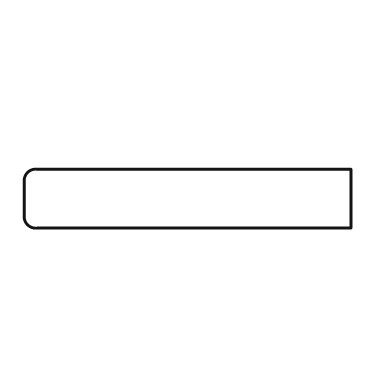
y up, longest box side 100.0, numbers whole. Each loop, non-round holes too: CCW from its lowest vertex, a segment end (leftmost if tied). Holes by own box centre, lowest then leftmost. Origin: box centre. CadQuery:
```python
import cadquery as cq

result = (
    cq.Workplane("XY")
    .moveTo(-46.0, -9.0)
    .lineTo(50.0, -9.0)
    .lineTo(50.0, 9.0)
    .lineTo(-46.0, 9.0)
    .threePointArc((-49.0, 8.0), (-50.0, 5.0))
    .lineTo(-50.0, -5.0)
    .threePointArc((-49.0, -8.0), (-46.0, -9.0))
    .close()
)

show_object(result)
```